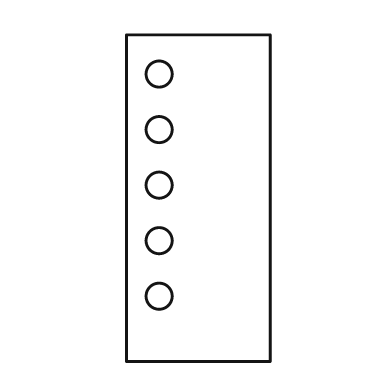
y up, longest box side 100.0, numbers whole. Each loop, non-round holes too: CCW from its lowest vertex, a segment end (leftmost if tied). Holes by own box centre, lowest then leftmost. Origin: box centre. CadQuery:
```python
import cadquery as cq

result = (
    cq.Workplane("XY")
    .moveTo(-22.0, -50.0)
    .lineTo(22.0, -50.0)
    .lineTo(22.0, 50.0)
    .lineTo(-22.0, 50.0)
    .close()
    .moveTo(-12.0, -30.0)
    .circle(4.0)
    .moveTo(-12.0, -13.0)
    .circle(4.0)
    .moveTo(-12.0, 4.0)
    .circle(4.0)
    .moveTo(-12.0, 21.0)
    .circle(4.0)
    .moveTo(-12.0, 38.0)
    .circle(4.0)
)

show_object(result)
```